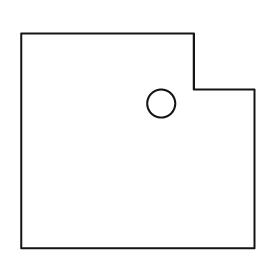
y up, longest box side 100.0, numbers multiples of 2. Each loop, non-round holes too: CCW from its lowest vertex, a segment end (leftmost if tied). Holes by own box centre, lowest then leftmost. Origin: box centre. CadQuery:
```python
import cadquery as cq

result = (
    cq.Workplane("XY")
    .moveTo(-50.0, -46.0)
    .lineTo(50.0, -46.0)
    .lineTo(50.0, 22.0)
    .lineTo(24.0, 22.0)
    .lineTo(24.0, 46.0)
    .lineTo(-50.0, 46.0)
    .close()
    .moveTo(10.0, 16.0)
    .circle(6.0)
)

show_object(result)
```